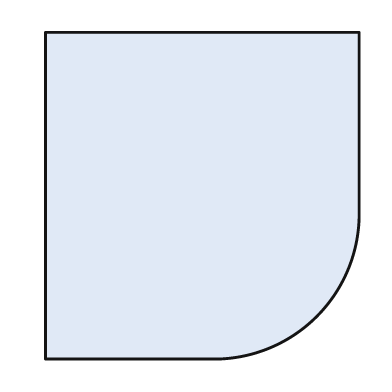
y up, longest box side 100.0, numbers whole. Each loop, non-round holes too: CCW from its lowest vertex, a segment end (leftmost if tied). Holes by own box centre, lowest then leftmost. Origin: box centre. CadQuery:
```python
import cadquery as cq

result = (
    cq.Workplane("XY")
    .moveTo(-48.0, -50.0)
    .lineTo(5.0, -50.0)
    .threePointArc((35.0, -37.0), (48.0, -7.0))
    .lineTo(48.0, 50.0)
    .lineTo(-48.0, 50.0)
    .close()
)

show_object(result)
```